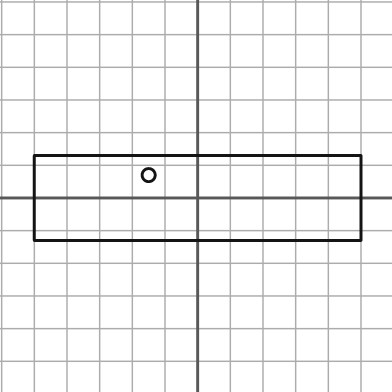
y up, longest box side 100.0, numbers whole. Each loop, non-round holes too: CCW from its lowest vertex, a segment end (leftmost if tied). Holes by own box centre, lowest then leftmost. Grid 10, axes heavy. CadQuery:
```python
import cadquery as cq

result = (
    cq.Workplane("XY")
    .moveTo(-50.0, -13.0)
    .lineTo(50.0, -13.0)
    .lineTo(50.0, 13.0)
    .lineTo(-50.0, 13.0)
    .close()
    .moveTo(-15.0, 7.0)
    .circle(2.0)
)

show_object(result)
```